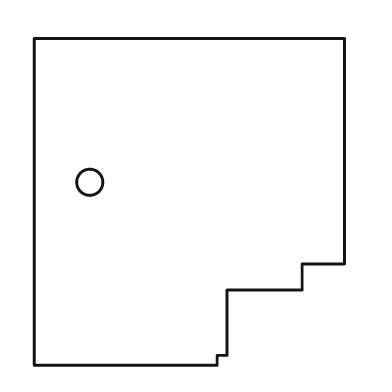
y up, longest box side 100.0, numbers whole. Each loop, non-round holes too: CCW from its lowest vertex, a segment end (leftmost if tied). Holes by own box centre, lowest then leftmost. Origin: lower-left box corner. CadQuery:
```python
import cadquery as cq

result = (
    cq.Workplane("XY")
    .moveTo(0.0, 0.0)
    .lineTo(56.0, 0.0)
    .lineTo(56.0, 3.0)
    .lineTo(59.0, 3.0)
    .lineTo(59.0, 23.0)
    .lineTo(82.0, 23.0)
    .lineTo(82.0, 31.0)
    .lineTo(95.0, 31.0)
    .lineTo(95.0, 100.0)
    .lineTo(0.0, 100.0)
    .close()
    .moveTo(17.0, 56.0)
    .circle(4.0)
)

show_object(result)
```